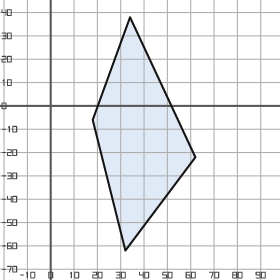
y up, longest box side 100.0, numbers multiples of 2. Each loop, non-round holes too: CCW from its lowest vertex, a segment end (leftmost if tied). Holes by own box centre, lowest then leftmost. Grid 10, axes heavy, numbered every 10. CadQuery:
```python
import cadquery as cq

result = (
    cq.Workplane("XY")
    .moveTo(32.0, -62.0)
    .lineTo(62.0, -22.0)
    .lineTo(34.0, 38.0)
    .lineTo(18.0, -6.0)
    .close()
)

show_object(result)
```